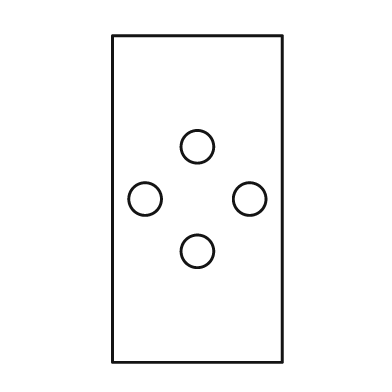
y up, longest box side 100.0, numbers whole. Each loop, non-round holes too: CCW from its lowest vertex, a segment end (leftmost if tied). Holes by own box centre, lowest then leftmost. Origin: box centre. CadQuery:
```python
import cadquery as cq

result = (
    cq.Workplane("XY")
    .moveTo(-26.0, -50.0)
    .lineTo(26.0, -50.0)
    .lineTo(26.0, 50.0)
    .lineTo(-26.0, 50.0)
    .close()
    .moveTo(0.0, -16.0)
    .circle(5.0)
    .moveTo(-16.0, 0.0)
    .circle(5.0)
    .moveTo(16.0, 0.0)
    .circle(5.0)
    .moveTo(0.0, 16.0)
    .circle(5.0)
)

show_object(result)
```